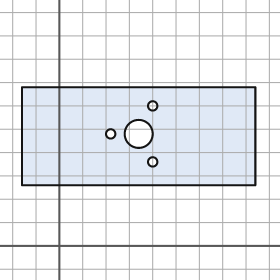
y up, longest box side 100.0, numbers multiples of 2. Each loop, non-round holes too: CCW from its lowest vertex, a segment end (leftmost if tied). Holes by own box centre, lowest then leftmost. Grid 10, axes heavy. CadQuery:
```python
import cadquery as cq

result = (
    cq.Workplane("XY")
    .moveTo(-16.0, 26.0)
    .lineTo(84.0, 26.0)
    .lineTo(84.0, 68.0)
    .lineTo(-16.0, 68.0)
    .close()
    .moveTo(40.0, 36.0)
    .circle(2.0)
    .moveTo(22.0, 48.0)
    .circle(2.0)
    .moveTo(34.0, 48.0)
    .circle(6.0)
    .moveTo(40.0, 60.0)
    .circle(2.0)
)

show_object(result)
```